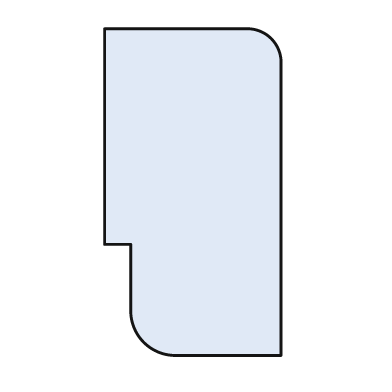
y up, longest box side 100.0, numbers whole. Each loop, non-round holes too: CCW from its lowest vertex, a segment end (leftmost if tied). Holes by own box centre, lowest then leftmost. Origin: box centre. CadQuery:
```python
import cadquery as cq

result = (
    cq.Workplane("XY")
    .moveTo(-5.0, -50.0)
    .lineTo(27.0, -50.0)
    .lineTo(27.0, 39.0)
    .threePointArc((24.0, 47.0), (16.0, 50.0))
    .lineTo(-27.0, 50.0)
    .lineTo(-27.0, -16.0)
    .lineTo(-19.0, -16.0)
    .lineTo(-19.0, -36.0)
    .threePointArc((-15.0, -46.0), (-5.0, -50.0))
    .close()
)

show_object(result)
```